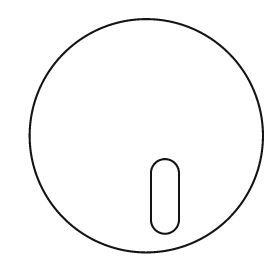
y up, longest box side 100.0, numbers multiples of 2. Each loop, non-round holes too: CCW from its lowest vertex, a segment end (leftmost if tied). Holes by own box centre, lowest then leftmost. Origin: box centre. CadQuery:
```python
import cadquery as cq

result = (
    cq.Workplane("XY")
    .moveTo(0.0, 0.0)
    .circle(50.0)
    .moveTo(2.0, -36.0)
    .threePointArc((8.0, -42.0), (14.0, -36.0))
    .lineTo(14.0, -16.0)
    .threePointArc((8.0, -10.0), (2.0, -16.0))
    .close()
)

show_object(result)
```